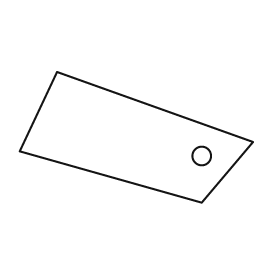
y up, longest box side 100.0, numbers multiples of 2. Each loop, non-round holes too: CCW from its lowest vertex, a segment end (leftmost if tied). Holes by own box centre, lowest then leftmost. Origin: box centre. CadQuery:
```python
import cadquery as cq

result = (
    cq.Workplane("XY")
    .moveTo(28.0, -28.0)
    .lineTo(50.0, -2.0)
    .lineTo(-34.0, 28.0)
    .lineTo(-50.0, -6.0)
    .close()
    .moveTo(28.0, -8.0)
    .circle(4.0)
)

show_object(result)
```